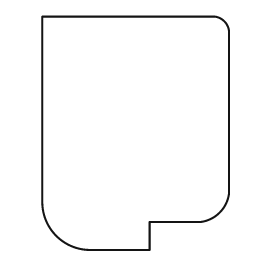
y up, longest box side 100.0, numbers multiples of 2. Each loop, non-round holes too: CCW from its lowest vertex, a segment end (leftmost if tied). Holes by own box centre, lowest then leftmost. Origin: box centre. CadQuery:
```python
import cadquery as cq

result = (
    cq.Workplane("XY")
    .moveTo(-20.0, -50.0)
    .lineTo(6.0, -50.0)
    .lineTo(6.0, -38.0)
    .lineTo(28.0, -38.0)
    .threePointArc((36.0, -34.0), (40.0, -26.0))
    .lineTo(40.0, 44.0)
    .threePointArc((38.0, 48.0), (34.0, 50.0))
    .lineTo(-40.0, 50.0)
    .lineTo(-40.0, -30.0)
    .threePointArc((-34.0, -44.0), (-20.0, -50.0))
    .close()
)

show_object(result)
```